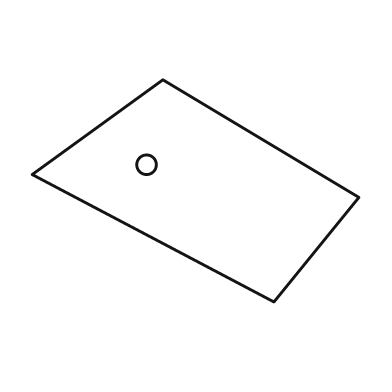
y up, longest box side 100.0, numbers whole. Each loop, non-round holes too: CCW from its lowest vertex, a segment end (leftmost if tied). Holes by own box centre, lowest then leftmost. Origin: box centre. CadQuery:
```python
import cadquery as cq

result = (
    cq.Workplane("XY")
    .moveTo(24.0, -34.0)
    .lineTo(50.0, -2.0)
    .lineTo(-10.0, 34.0)
    .lineTo(-50.0, 5.0)
    .close()
    .moveTo(-15.0, 8.0)
    .circle(3.0)
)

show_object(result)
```